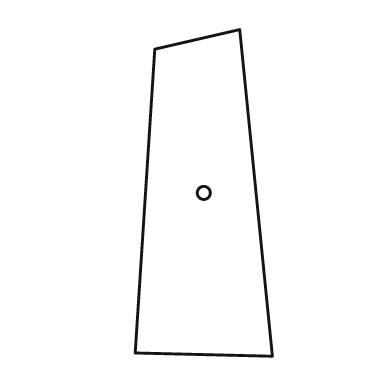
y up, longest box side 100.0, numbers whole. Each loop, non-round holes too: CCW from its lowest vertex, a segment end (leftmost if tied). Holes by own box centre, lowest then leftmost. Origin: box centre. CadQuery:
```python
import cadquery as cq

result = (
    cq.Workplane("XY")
    .moveTo(21.0, -50.0)
    .lineTo(11.0, 50.0)
    .lineTo(-15.0, 44.0)
    .lineTo(-21.0, -49.0)
    .close()
    .moveTo(0.0, 0.0)
    .circle(2.0)
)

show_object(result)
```